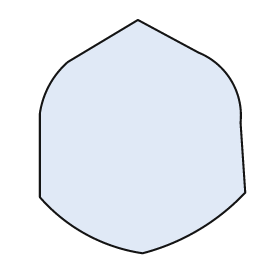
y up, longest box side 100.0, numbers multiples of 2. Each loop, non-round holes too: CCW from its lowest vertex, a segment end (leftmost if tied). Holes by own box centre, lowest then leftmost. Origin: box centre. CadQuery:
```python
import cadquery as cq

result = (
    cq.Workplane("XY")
    .moveTo(0.0, -50.0)
    .threePointArc((24.0, -40.0), (44.0, -24.0))
    .lineTo(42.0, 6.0)
    .threePointArc((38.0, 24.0), (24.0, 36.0))
    .lineTo(-2.0, 50.0)
    .lineTo(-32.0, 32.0)
    .threePointArc((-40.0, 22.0), (-44.0, 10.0))
    .lineTo(-44.0, -26.0)
    .threePointArc((-24.0, -42.0), (0.0, -50.0))
    .close()
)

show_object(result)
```